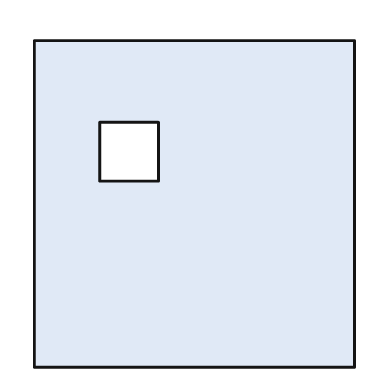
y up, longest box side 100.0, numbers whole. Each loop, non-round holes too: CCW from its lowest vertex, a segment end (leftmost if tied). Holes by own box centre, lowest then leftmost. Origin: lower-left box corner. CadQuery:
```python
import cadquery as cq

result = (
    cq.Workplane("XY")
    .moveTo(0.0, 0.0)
    .lineTo(98.0, 0.0)
    .lineTo(98.0, 100.0)
    .lineTo(0.0, 100.0)
    .close()
    .moveTo(20.0, 57.0)
    .lineTo(38.0, 57.0)
    .lineTo(38.0, 75.0)
    .lineTo(20.0, 75.0)
    .close()
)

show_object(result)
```